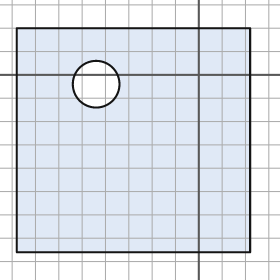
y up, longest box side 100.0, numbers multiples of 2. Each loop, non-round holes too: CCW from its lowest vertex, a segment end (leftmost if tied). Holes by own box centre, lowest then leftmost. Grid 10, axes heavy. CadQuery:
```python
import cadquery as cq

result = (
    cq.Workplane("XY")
    .moveTo(-78.0, -76.0)
    .lineTo(22.0, -76.0)
    .lineTo(22.0, 20.0)
    .lineTo(-78.0, 20.0)
    .close()
    .moveTo(-44.0, -4.0)
    .circle(10.0)
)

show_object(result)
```